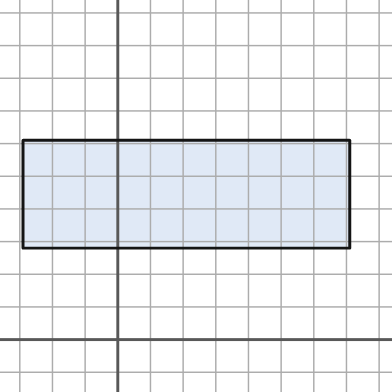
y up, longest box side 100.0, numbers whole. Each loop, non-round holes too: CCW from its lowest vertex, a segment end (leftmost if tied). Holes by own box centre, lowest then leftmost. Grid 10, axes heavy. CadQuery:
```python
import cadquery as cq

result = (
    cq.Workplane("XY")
    .moveTo(-29.0, 28.0)
    .lineTo(71.0, 28.0)
    .lineTo(71.0, 61.0)
    .lineTo(-29.0, 61.0)
    .close()
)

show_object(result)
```